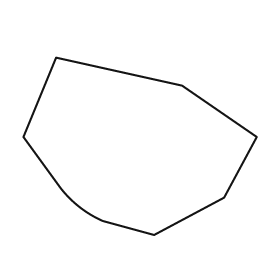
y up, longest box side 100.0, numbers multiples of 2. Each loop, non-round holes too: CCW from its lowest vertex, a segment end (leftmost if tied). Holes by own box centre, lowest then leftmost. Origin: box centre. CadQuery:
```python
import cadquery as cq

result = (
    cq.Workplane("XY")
    .moveTo(6.0, -38.0)
    .lineTo(36.0, -22.0)
    .lineTo(50.0, 4.0)
    .lineTo(18.0, 26.0)
    .lineTo(-36.0, 38.0)
    .lineTo(-50.0, 4.0)
    .lineTo(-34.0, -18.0)
    .threePointArc((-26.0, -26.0), (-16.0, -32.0))
    .close()
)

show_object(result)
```